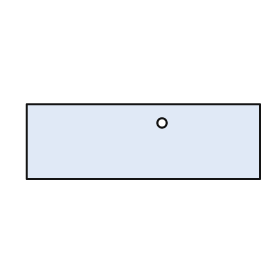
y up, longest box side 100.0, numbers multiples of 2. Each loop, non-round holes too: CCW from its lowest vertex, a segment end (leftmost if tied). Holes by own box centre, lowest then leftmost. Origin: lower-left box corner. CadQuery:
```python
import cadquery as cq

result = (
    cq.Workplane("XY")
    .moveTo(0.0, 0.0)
    .lineTo(100.0, 0.0)
    .lineTo(100.0, 32.0)
    .lineTo(0.0, 32.0)
    .close()
    .moveTo(58.0, 24.0)
    .circle(2.0)
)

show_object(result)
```